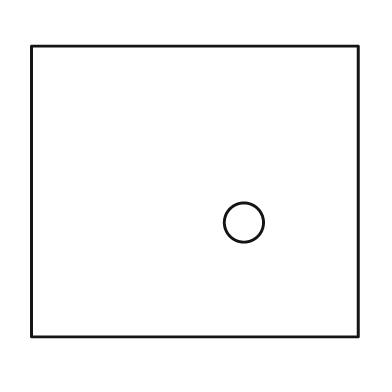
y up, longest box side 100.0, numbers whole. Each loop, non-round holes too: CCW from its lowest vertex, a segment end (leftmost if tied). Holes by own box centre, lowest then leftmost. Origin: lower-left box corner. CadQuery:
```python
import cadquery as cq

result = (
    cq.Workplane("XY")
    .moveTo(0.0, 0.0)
    .lineTo(100.0, 0.0)
    .lineTo(100.0, 89.0)
    .lineTo(0.0, 89.0)
    .close()
    .moveTo(65.0, 35.0)
    .circle(6.0)
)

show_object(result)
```